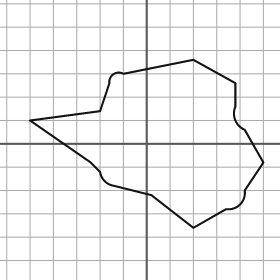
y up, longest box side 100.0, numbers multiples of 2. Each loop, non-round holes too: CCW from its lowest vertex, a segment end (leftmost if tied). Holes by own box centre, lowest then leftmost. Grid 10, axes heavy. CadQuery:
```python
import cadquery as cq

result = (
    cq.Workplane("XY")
    .moveTo(20.0, -36.0)
    .lineTo(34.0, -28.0)
    .threePointArc((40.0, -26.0), (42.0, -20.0))
    .lineTo(50.0, -8.0)
    .lineTo(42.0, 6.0)
    .threePointArc((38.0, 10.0), (38.0, 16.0))
    .lineTo(38.0, 26.0)
    .lineTo(20.0, 36.0)
    .lineTo(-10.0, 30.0)
    .threePointArc((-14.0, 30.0), (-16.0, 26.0))
    .lineTo(-20.0, 14.0)
    .lineTo(-50.0, 10.0)
    .lineTo(-24.0, -8.0)
    .lineTo(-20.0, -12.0)
    .threePointArc((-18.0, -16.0), (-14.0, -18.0))
    .lineTo(2.0, -22.0)
    .close()
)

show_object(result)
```